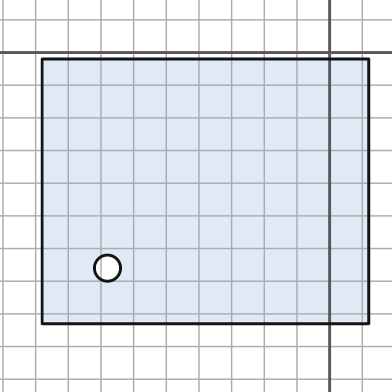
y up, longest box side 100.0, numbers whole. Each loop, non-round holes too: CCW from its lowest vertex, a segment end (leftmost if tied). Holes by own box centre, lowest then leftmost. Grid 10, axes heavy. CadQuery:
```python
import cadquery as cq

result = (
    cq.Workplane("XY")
    .moveTo(-88.0, -83.0)
    .lineTo(12.0, -83.0)
    .lineTo(12.0, -2.0)
    .lineTo(-88.0, -2.0)
    .close()
    .moveTo(-68.0, -66.0)
    .circle(4.0)
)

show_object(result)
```